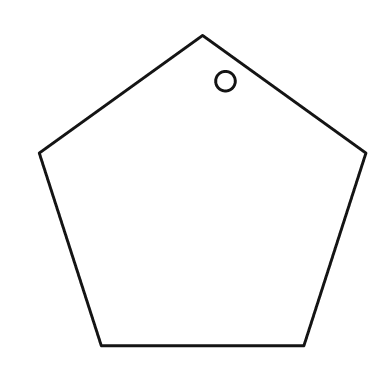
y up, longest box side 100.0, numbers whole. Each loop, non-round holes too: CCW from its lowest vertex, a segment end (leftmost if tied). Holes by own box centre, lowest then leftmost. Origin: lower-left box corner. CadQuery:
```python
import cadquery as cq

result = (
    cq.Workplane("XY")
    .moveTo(19.0, 0.0)
    .lineTo(81.0, 0.0)
    .lineTo(100.0, 59.0)
    .lineTo(50.0, 95.0)
    .lineTo(0.0, 59.0)
    .close()
    .moveTo(57.0, 81.0)
    .circle(3.0)
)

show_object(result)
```